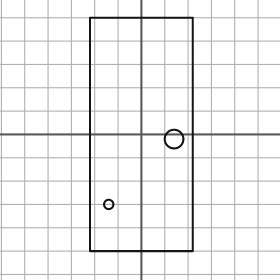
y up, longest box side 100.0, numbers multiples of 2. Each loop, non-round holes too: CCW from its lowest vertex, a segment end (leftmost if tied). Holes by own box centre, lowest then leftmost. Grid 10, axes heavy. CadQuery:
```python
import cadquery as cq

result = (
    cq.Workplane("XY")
    .moveTo(-22.0, -50.0)
    .lineTo(22.0, -50.0)
    .lineTo(22.0, 50.0)
    .lineTo(-22.0, 50.0)
    .close()
    .moveTo(-14.0, -30.0)
    .circle(2.0)
    .moveTo(14.0, -2.0)
    .circle(4.0)
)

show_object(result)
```